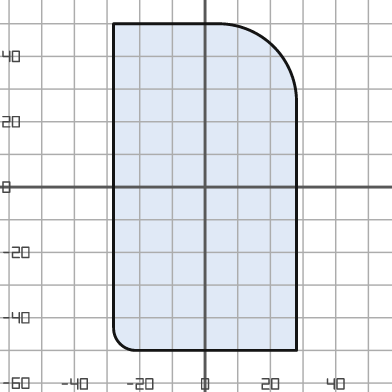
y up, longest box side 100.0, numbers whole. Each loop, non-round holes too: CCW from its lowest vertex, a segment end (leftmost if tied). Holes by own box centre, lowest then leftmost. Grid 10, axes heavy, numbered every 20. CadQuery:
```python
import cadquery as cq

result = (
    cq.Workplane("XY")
    .moveTo(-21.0, -50.0)
    .lineTo(28.0, -50.0)
    .lineTo(28.0, 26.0)
    .threePointArc((21.0, 43.0), (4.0, 50.0))
    .lineTo(-28.0, 50.0)
    .lineTo(-28.0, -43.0)
    .threePointArc((-26.0, -48.0), (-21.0, -50.0))
    .close()
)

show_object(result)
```